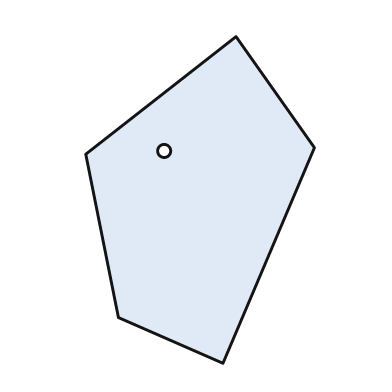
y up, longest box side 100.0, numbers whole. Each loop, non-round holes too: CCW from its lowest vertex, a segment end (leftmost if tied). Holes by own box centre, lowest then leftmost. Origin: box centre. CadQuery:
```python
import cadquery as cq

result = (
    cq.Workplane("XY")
    .moveTo(7.0, -50.0)
    .lineTo(35.0, 16.0)
    .lineTo(11.0, 50.0)
    .lineTo(-35.0, 14.0)
    .lineTo(-25.0, -36.0)
    .close()
    .moveTo(-11.0, 15.0)
    .circle(2.0)
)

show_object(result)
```